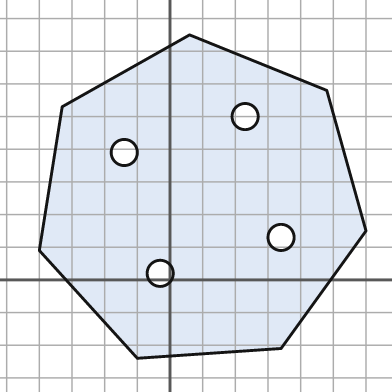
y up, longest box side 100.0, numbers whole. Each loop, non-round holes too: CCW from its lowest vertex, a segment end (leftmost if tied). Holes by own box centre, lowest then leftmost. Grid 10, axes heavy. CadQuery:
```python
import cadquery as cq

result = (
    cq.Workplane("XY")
    .moveTo(-10.0, -24.0)
    .lineTo(34.0, -21.0)
    .lineTo(60.0, 15.0)
    .lineTo(48.0, 58.0)
    .lineTo(6.0, 75.0)
    .lineTo(-33.0, 53.0)
    .lineTo(-40.0, 9.0)
    .close()
    .moveTo(-3.0, 2.0)
    .circle(4.0)
    .moveTo(34.0, 13.0)
    .circle(4.0)
    .moveTo(-14.0, 39.0)
    .circle(4.0)
    .moveTo(23.0, 50.0)
    .circle(4.0)
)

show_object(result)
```